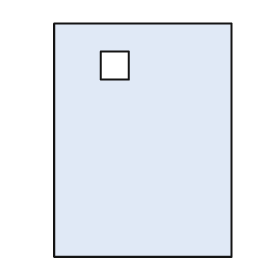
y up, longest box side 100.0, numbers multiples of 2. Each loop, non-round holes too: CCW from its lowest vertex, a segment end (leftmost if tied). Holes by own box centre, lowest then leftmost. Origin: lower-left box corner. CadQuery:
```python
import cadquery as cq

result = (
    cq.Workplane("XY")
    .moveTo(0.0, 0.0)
    .lineTo(76.0, 0.0)
    .lineTo(76.0, 100.0)
    .lineTo(0.0, 100.0)
    .close()
    .moveTo(20.0, 76.0)
    .lineTo(32.0, 76.0)
    .lineTo(32.0, 88.0)
    .lineTo(20.0, 88.0)
    .close()
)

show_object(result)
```